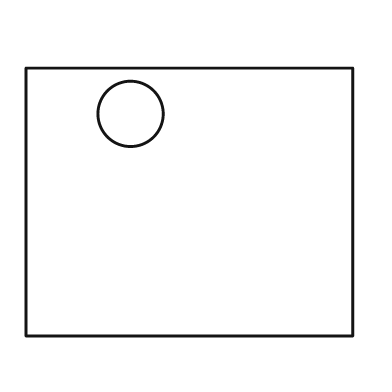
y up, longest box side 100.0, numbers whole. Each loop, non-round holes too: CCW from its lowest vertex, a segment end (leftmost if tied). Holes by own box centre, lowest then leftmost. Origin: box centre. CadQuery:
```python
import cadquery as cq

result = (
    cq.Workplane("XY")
    .moveTo(-50.0, -41.0)
    .lineTo(50.0, -41.0)
    .lineTo(50.0, 41.0)
    .lineTo(-50.0, 41.0)
    .close()
    .moveTo(-18.0, 27.0)
    .circle(10.0)
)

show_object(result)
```